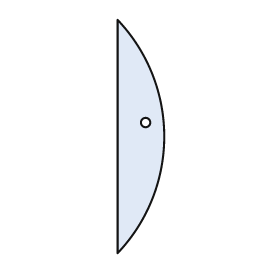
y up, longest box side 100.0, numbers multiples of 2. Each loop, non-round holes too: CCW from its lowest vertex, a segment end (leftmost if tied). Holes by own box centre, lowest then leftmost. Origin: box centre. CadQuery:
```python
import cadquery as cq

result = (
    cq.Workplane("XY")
    .moveTo(-10.0, -50.0)
    .threePointArc((10.0, 0.0), (-10.0, 50.0))
    .close()
    .moveTo(2.0, 6.0)
    .circle(2.0)
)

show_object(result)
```